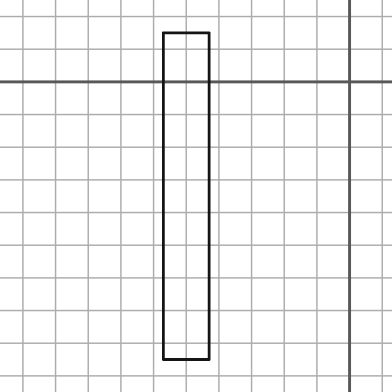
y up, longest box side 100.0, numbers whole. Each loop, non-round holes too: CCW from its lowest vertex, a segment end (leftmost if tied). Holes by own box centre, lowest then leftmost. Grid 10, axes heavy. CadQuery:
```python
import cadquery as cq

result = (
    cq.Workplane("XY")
    .moveTo(-57.0, -85.0)
    .lineTo(-43.0, -85.0)
    .lineTo(-43.0, 15.0)
    .lineTo(-57.0, 15.0)
    .close()
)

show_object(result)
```